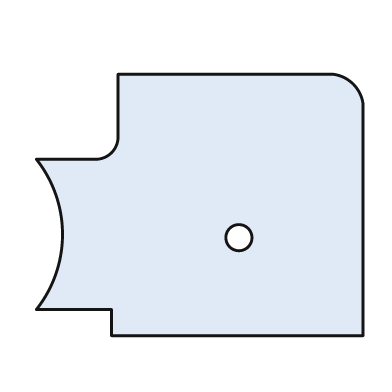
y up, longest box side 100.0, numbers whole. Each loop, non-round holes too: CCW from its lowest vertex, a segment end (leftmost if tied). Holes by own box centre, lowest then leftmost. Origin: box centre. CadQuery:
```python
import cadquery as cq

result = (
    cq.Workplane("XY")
    .moveTo(-27.0, -40.0)
    .lineTo(50.0, -40.0)
    .lineTo(50.0, 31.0)
    .threePointArc((47.0, 37.0), (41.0, 40.0))
    .lineTo(-25.0, 40.0)
    .lineTo(-25.0, 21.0)
    .threePointArc((-27.0, 16.0), (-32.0, 14.0))
    .lineTo(-50.0, 14.0)
    .threePointArc((-42.0, -9.0), (-50.0, -32.0))
    .lineTo(-27.0, -32.0)
    .close()
    .moveTo(12.0, -10.0)
    .circle(4.0)
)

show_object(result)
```